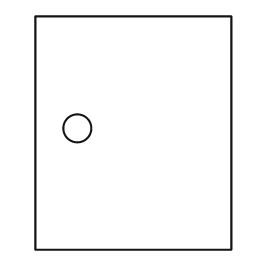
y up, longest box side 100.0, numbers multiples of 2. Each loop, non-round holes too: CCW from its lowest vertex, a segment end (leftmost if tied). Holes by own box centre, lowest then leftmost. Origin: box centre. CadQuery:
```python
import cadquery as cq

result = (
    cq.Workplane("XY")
    .moveTo(-42.0, -50.0)
    .lineTo(42.0, -50.0)
    .lineTo(42.0, 50.0)
    .lineTo(-42.0, 50.0)
    .close()
    .moveTo(-24.0, 2.0)
    .circle(6.0)
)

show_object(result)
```